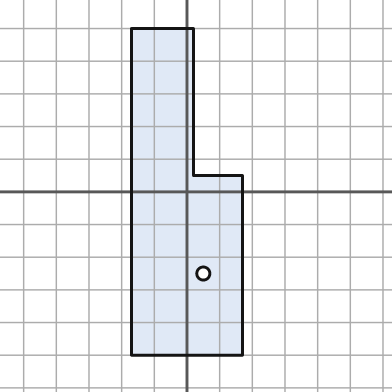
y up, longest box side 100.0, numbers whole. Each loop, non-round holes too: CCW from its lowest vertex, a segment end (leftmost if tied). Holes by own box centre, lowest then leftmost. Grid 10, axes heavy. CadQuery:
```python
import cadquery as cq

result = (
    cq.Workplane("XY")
    .moveTo(-17.0, -50.0)
    .lineTo(17.0, -50.0)
    .lineTo(17.0, 5.0)
    .lineTo(2.0, 5.0)
    .lineTo(2.0, 50.0)
    .lineTo(-17.0, 50.0)
    .close()
    .moveTo(5.0, -25.0)
    .circle(2.0)
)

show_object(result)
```